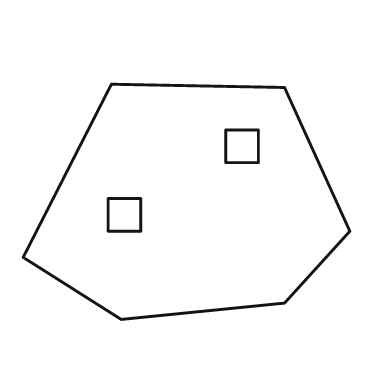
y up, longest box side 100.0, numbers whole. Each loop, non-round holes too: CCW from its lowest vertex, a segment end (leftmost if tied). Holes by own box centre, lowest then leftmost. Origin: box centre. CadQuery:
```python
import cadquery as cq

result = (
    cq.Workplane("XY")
    .moveTo(-20.0, -36.0)
    .lineTo(30.0, -31.0)
    .lineTo(50.0, -9.0)
    .lineTo(30.0, 35.0)
    .lineTo(-23.0, 36.0)
    .lineTo(-50.0, -17.0)
    .close()
    .moveTo(-24.0, -9.0)
    .lineTo(-14.0, -9.0)
    .lineTo(-14.0, 1.0)
    .lineTo(-24.0, 1.0)
    .close()
    .moveTo(12.0, 12.0)
    .lineTo(22.0, 12.0)
    .lineTo(22.0, 22.0)
    .lineTo(12.0, 22.0)
    .close()
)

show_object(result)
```